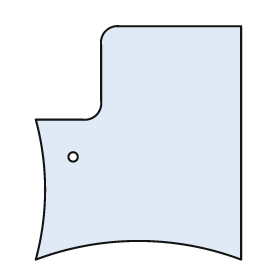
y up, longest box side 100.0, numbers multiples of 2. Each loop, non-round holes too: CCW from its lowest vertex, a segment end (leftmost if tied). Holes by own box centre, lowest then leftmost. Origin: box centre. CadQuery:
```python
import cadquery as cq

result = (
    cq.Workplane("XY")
    .moveTo(-44.0, -50.0)
    .threePointArc((0.0, -42.0), (44.0, -50.0))
    .lineTo(44.0, 50.0)
    .lineTo(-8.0, 50.0)
    .threePointArc((-14.0, 48.0), (-16.0, 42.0))
    .lineTo(-16.0, 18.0)
    .threePointArc((-18.0, 12.0), (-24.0, 10.0))
    .lineTo(-44.0, 10.0)
    .threePointArc((-40.0, -20.0), (-44.0, -50.0))
    .close()
    .moveTo(-28.0, -6.0)
    .circle(2.0)
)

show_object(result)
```